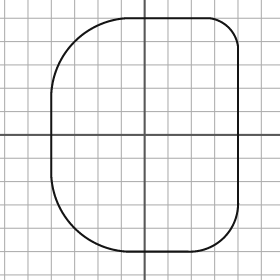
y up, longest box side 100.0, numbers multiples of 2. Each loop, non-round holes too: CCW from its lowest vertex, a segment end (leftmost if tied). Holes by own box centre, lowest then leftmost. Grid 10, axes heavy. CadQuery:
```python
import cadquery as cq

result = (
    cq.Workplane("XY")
    .moveTo(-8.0, -50.0)
    .lineTo(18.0, -50.0)
    .threePointArc((34.0, -44.0), (40.0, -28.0))
    .lineTo(40.0, 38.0)
    .threePointArc((36.0, 46.0), (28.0, 50.0))
    .lineTo(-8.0, 50.0)
    .threePointArc((-30.0, 40.0), (-40.0, 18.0))
    .lineTo(-40.0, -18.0)
    .threePointArc((-30.0, -40.0), (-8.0, -50.0))
    .close()
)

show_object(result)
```